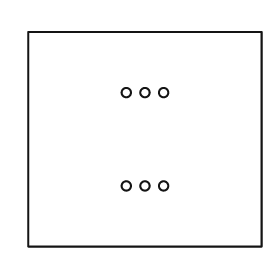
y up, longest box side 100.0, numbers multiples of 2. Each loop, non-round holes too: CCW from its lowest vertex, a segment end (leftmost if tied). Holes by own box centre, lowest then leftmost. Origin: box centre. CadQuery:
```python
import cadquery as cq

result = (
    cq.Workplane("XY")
    .moveTo(-50.0, -46.0)
    .lineTo(50.0, -46.0)
    .lineTo(50.0, 46.0)
    .lineTo(-50.0, 46.0)
    .close()
    .moveTo(-8.0, -20.0)
    .circle(2.0)
    .moveTo(0.0, -20.0)
    .circle(2.0)
    .moveTo(8.0, -20.0)
    .circle(2.0)
    .moveTo(-8.0, 20.0)
    .circle(2.0)
    .moveTo(0.0, 20.0)
    .circle(2.0)
    .moveTo(8.0, 20.0)
    .circle(2.0)
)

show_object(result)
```